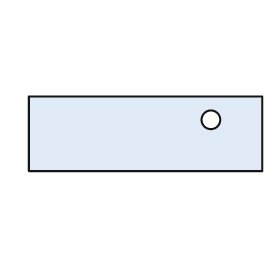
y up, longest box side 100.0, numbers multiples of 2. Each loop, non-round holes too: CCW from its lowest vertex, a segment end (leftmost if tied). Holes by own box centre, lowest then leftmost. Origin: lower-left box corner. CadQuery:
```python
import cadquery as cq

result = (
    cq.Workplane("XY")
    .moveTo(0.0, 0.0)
    .lineTo(100.0, 0.0)
    .lineTo(100.0, 32.0)
    .lineTo(0.0, 32.0)
    .close()
    .moveTo(78.0, 22.0)
    .circle(4.0)
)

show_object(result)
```